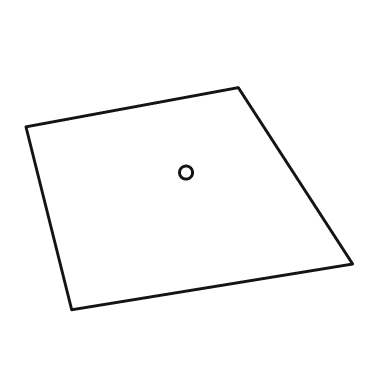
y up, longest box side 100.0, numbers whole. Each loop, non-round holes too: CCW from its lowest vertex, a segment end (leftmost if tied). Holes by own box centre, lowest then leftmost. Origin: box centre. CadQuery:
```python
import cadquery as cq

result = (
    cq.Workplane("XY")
    .moveTo(-36.0, -34.0)
    .lineTo(50.0, -20.0)
    .lineTo(15.0, 34.0)
    .lineTo(-50.0, 22.0)
    .close()
    .moveTo(-1.0, 8.0)
    .circle(2.0)
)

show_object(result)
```